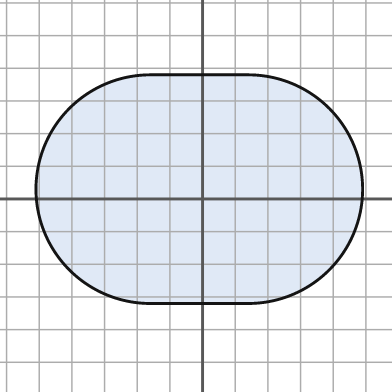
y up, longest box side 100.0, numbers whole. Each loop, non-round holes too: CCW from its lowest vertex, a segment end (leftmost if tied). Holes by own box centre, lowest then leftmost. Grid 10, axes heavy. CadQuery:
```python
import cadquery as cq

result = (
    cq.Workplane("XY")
    .moveTo(-16.0, -32.0)
    .lineTo(14.0, -32.0)
    .threePointArc((49.0, 3.0), (14.0, 38.0))
    .lineTo(-16.0, 38.0)
    .threePointArc((-51.0, 3.0), (-16.0, -32.0))
    .close()
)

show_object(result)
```